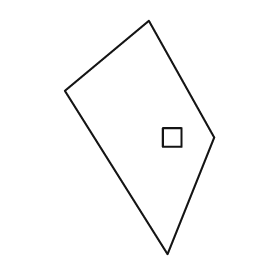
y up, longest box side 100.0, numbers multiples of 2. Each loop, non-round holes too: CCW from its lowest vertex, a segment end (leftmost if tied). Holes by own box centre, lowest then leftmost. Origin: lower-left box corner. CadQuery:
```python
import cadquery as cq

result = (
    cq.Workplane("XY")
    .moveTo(44.0, 0.0)
    .lineTo(64.0, 50.0)
    .lineTo(36.0, 100.0)
    .lineTo(0.0, 70.0)
    .close()
    .moveTo(42.0, 46.0)
    .lineTo(50.0, 46.0)
    .lineTo(50.0, 54.0)
    .lineTo(42.0, 54.0)
    .close()
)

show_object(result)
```